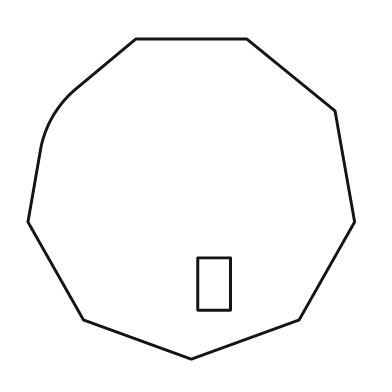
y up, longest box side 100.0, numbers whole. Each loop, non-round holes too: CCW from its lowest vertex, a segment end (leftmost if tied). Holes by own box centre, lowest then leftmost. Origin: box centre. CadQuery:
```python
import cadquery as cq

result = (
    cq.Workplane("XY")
    .moveTo(0.0, -49.0)
    .lineTo(33.0, -37.0)
    .lineTo(50.0, -7.0)
    .lineTo(44.0, 27.0)
    .lineTo(17.0, 49.0)
    .lineTo(-17.0, 49.0)
    .lineTo(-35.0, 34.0)
    .threePointArc((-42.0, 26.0), (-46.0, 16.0))
    .lineTo(-50.0, -7.0)
    .lineTo(-33.0, -37.0)
    .close()
    .moveTo(2.0, -34.0)
    .lineTo(12.0, -34.0)
    .lineTo(12.0, -18.0)
    .lineTo(2.0, -18.0)
    .close()
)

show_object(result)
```